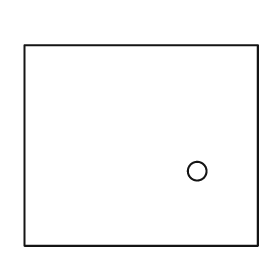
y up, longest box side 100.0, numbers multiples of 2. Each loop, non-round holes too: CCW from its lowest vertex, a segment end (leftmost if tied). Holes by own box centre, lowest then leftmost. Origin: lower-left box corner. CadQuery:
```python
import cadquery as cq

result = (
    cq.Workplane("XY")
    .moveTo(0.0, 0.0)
    .lineTo(100.0, 0.0)
    .lineTo(100.0, 86.0)
    .lineTo(0.0, 86.0)
    .close()
    .moveTo(74.0, 32.0)
    .circle(4.0)
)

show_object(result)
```